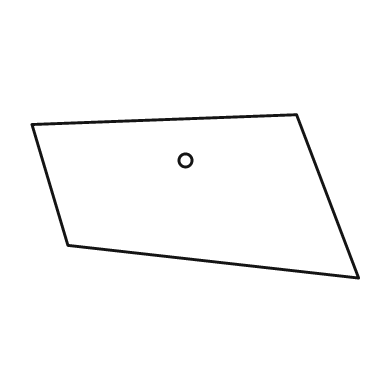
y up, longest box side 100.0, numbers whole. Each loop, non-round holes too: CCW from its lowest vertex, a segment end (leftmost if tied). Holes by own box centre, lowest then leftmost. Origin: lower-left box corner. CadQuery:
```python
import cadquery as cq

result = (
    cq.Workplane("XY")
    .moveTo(100.0, 0.0)
    .lineTo(81.0, 50.0)
    .lineTo(0.0, 47.0)
    .lineTo(11.0, 10.0)
    .close()
    .moveTo(47.0, 36.0)
    .circle(2.0)
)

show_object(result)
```